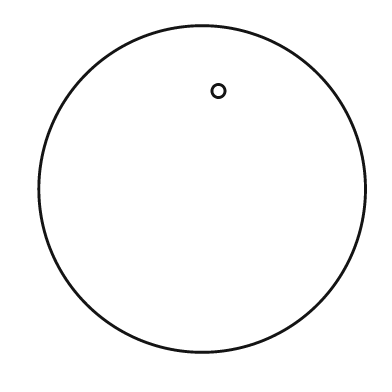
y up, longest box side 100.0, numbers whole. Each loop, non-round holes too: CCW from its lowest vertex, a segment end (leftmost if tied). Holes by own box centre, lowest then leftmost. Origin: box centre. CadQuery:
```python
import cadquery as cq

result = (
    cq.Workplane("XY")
    .moveTo(0.0, 0.0)
    .circle(50.0)
    .moveTo(5.0, 30.0)
    .circle(2.0)
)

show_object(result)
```